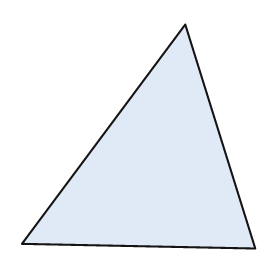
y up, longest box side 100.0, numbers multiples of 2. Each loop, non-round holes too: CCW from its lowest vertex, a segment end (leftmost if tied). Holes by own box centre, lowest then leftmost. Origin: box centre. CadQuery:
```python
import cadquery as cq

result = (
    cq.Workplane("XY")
    .moveTo(50.0, -48.0)
    .lineTo(20.0, 48.0)
    .lineTo(-50.0, -46.0)
    .close()
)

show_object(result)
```